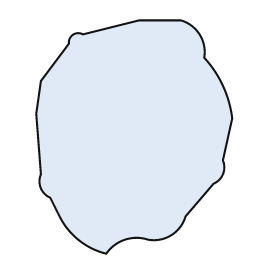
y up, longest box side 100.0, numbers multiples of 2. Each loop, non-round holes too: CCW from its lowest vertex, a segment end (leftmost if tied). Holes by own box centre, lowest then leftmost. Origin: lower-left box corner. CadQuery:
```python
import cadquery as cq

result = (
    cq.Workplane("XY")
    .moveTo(30.0, 0.0)
    .threePointArc((38.0, 6.0), (48.0, 6.0))
    .threePointArc((58.0, 8.0), (64.0, 16.0))
    .lineTo(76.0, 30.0)
    .threePointArc((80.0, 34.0), (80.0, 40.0))
    .lineTo(84.0, 58.0)
    .threePointArc((80.0, 72.0), (72.0, 84.0))
    .threePointArc((70.0, 94.0), (62.0, 100.0))
    .lineTo(44.0, 100.0)
    .lineTo(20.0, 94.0)
    .threePointArc((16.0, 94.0), (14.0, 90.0))
    .lineTo(2.0, 74.0)
    .lineTo(0.0, 60.0)
    .lineTo(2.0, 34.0)
    .threePointArc((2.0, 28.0), (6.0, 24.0))
    .lineTo(10.0, 16.0)
    .threePointArc((18.0, 6.0), (30.0, 0.0))
    .close()
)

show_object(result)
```